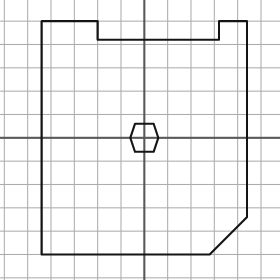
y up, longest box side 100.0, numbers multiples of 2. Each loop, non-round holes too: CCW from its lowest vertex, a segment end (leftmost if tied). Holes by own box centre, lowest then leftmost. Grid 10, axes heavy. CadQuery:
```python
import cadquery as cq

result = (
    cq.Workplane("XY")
    .moveTo(-44.0, -50.0)
    .lineTo(28.0, -50.0)
    .lineTo(44.0, -34.0)
    .lineTo(44.0, 50.0)
    .lineTo(32.0, 50.0)
    .lineTo(32.0, 42.0)
    .lineTo(-20.0, 42.0)
    .lineTo(-20.0, 50.0)
    .lineTo(-44.0, 50.0)
    .close()
    .moveTo(-4.0, -6.0)
    .lineTo(4.0, -6.0)
    .lineTo(6.0, 0.0)
    .lineTo(4.0, 6.0)
    .lineTo(-4.0, 6.0)
    .lineTo(-6.0, 0.0)
    .close()
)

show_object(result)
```